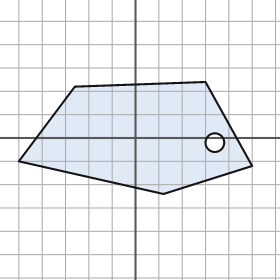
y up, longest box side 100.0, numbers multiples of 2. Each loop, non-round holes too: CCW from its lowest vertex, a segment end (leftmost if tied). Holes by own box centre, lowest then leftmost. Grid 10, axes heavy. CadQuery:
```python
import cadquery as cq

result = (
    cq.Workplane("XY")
    .moveTo(12.0, -24.0)
    .lineTo(50.0, -12.0)
    .lineTo(30.0, 24.0)
    .lineTo(-26.0, 22.0)
    .lineTo(-50.0, -10.0)
    .close()
    .moveTo(34.0, -2.0)
    .circle(4.0)
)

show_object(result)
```